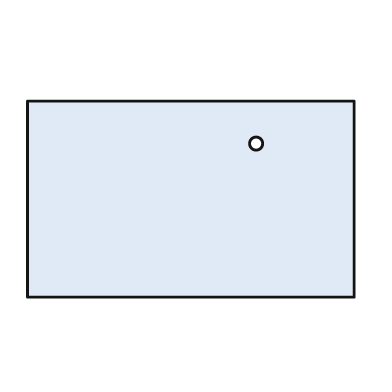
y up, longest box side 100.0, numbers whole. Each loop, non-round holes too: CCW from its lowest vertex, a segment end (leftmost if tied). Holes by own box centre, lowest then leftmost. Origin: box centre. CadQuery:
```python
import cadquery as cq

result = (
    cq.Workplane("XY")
    .moveTo(-50.0, -30.0)
    .lineTo(50.0, -30.0)
    .lineTo(50.0, 30.0)
    .lineTo(-50.0, 30.0)
    .close()
    .moveTo(20.0, 17.0)
    .circle(2.0)
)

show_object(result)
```